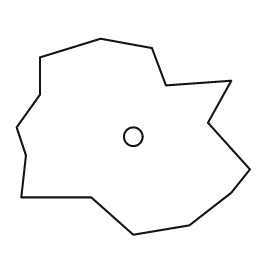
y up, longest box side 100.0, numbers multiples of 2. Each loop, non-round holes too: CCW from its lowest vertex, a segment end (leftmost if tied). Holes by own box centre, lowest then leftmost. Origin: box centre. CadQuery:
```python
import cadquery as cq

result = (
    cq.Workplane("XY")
    .moveTo(0.0, -42.0)
    .lineTo(24.0, -38.0)
    .lineTo(42.0, -24.0)
    .lineTo(50.0, -14.0)
    .lineTo(32.0, 6.0)
    .lineTo(42.0, 24.0)
    .lineTo(14.0, 22.0)
    .lineTo(8.0, 38.0)
    .lineTo(-14.0, 42.0)
    .lineTo(-40.0, 34.0)
    .lineTo(-40.0, 18.0)
    .lineTo(-50.0, 4.0)
    .lineTo(-46.0, -8.0)
    .lineTo(-48.0, -26.0)
    .lineTo(-18.0, -26.0)
    .close()
    .moveTo(0.0, 0.0)
    .circle(4.0)
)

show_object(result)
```